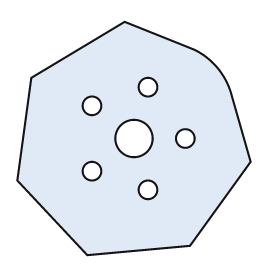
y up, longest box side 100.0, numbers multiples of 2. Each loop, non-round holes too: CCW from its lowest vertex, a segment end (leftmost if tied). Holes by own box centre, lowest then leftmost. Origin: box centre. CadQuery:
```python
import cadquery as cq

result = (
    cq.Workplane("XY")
    .moveTo(-20.0, -50.0)
    .lineTo(24.0, -46.0)
    .lineTo(50.0, -10.0)
    .lineTo(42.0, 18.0)
    .threePointArc((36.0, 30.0), (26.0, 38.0))
    .lineTo(-4.0, 50.0)
    .lineTo(-44.0, 26.0)
    .lineTo(-50.0, -18.0)
    .close()
    .moveTo(6.0, -22.0)
    .circle(4.0)
    .moveTo(-18.0, -14.0)
    .circle(4.0)
    .moveTo(0.0, 0.0)
    .circle(8.0)
    .moveTo(22.0, 0.0)
    .circle(4.0)
    .moveTo(-18.0, 14.0)
    .circle(4.0)
    .moveTo(6.0, 22.0)
    .circle(4.0)
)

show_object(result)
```